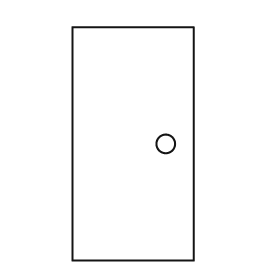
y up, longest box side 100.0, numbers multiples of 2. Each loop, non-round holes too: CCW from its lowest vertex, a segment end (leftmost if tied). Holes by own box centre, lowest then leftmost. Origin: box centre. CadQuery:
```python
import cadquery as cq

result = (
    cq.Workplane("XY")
    .moveTo(-26.0, -50.0)
    .lineTo(26.0, -50.0)
    .lineTo(26.0, 50.0)
    .lineTo(-26.0, 50.0)
    .close()
    .moveTo(14.0, 0.0)
    .circle(4.0)
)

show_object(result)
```